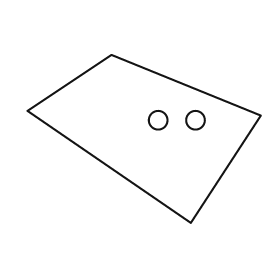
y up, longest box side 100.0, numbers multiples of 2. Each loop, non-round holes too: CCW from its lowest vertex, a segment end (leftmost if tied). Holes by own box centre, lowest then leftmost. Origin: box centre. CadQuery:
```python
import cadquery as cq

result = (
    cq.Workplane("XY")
    .moveTo(20.0, -36.0)
    .lineTo(50.0, 10.0)
    .lineTo(-14.0, 36.0)
    .lineTo(-50.0, 12.0)
    .close()
    .moveTo(6.0, 8.0)
    .circle(4.0)
    .moveTo(22.0, 8.0)
    .circle(4.0)
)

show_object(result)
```